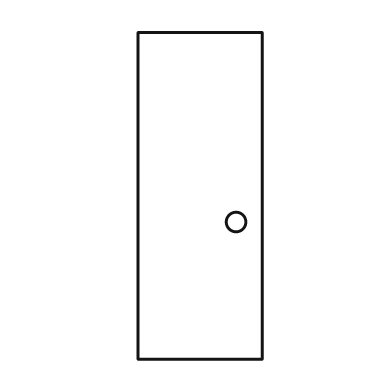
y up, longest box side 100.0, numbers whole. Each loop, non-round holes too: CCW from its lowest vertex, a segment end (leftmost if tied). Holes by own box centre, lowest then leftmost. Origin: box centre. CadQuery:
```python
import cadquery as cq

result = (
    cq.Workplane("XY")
    .moveTo(-19.0, -50.0)
    .lineTo(19.0, -50.0)
    .lineTo(19.0, 50.0)
    .lineTo(-19.0, 50.0)
    .close()
    .moveTo(11.0, -8.0)
    .circle(3.0)
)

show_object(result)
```